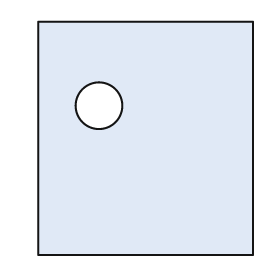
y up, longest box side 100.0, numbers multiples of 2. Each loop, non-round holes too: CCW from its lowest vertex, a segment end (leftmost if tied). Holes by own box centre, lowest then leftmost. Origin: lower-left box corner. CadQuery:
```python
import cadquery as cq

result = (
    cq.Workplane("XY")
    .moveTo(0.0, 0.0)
    .lineTo(92.0, 0.0)
    .lineTo(92.0, 100.0)
    .lineTo(0.0, 100.0)
    .close()
    .moveTo(26.0, 64.0)
    .circle(10.0)
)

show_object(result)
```